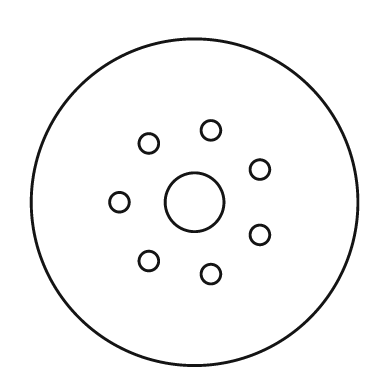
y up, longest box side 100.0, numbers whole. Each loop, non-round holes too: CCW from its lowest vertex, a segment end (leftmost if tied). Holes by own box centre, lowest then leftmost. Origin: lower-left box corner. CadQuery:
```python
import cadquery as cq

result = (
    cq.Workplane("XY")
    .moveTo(50.0, 50.0)
    .circle(50.0)
    .moveTo(55.0, 28.0)
    .circle(3.0)
    .moveTo(36.0, 32.0)
    .circle(3.0)
    .moveTo(70.0, 40.0)
    .circle(3.0)
    .moveTo(27.0, 50.0)
    .circle(3.0)
    .moveTo(50.0, 50.0)
    .circle(9.0)
    .moveTo(70.0, 60.0)
    .circle(3.0)
    .moveTo(36.0, 68.0)
    .circle(3.0)
    .moveTo(55.0, 72.0)
    .circle(3.0)
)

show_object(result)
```